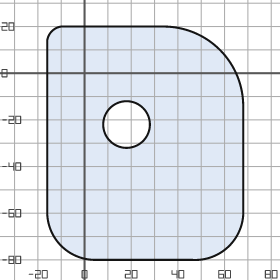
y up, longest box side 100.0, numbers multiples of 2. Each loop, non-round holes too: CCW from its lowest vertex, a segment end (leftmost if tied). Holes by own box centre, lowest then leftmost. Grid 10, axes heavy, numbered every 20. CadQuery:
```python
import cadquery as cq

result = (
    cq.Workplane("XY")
    .moveTo(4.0, -80.0)
    .lineTo(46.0, -80.0)
    .threePointArc((62.0, -74.0), (68.0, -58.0))
    .lineTo(68.0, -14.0)
    .threePointArc((58.0, 10.0), (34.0, 20.0))
    .lineTo(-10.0, 20.0)
    .threePointArc((-14.0, 18.0), (-16.0, 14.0))
    .lineTo(-16.0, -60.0)
    .threePointArc((-10.0, -74.0), (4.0, -80.0))
    .close()
    .moveTo(18.0, -22.0)
    .circle(10.0)
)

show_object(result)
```